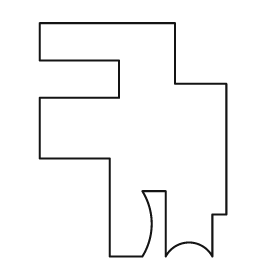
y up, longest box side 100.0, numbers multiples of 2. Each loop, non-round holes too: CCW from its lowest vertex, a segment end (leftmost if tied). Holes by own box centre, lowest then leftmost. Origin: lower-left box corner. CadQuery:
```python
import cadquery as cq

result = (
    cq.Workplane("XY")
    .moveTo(30.0, 0.0)
    .lineTo(44.0, 0.0)
    .threePointArc((48.0, 14.0), (44.0, 28.0))
    .lineTo(54.0, 28.0)
    .lineTo(54.0, 0.0)
    .threePointArc((64.0, 6.0), (74.0, 0.0))
    .lineTo(74.0, 18.0)
    .lineTo(80.0, 18.0)
    .lineTo(80.0, 74.0)
    .lineTo(58.0, 74.0)
    .lineTo(58.0, 100.0)
    .lineTo(0.0, 100.0)
    .lineTo(0.0, 84.0)
    .lineTo(34.0, 84.0)
    .lineTo(34.0, 68.0)
    .lineTo(0.0, 68.0)
    .lineTo(0.0, 42.0)
    .lineTo(30.0, 42.0)
    .close()
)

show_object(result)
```